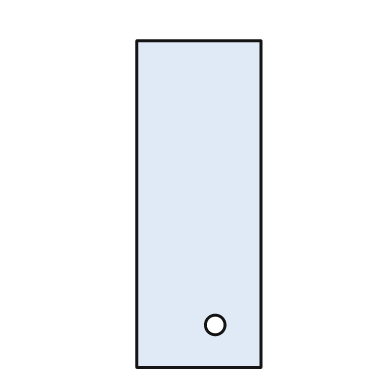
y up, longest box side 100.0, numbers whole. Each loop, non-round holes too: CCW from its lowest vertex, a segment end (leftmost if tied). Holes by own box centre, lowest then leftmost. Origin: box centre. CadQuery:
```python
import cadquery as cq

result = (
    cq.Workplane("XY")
    .moveTo(-19.0, -50.0)
    .lineTo(19.0, -50.0)
    .lineTo(19.0, 50.0)
    .lineTo(-19.0, 50.0)
    .close()
    .moveTo(5.0, -37.0)
    .circle(3.0)
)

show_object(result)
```